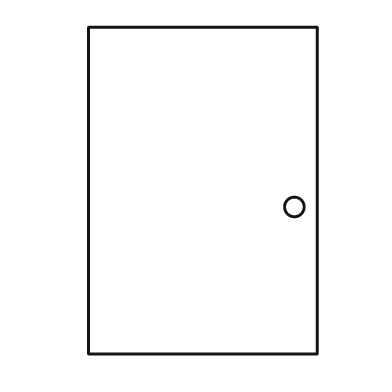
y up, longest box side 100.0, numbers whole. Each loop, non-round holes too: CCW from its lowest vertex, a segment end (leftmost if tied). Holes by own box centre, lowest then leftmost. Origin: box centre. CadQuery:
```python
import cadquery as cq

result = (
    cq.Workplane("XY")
    .moveTo(-35.0, -50.0)
    .lineTo(35.0, -50.0)
    .lineTo(35.0, 50.0)
    .lineTo(-35.0, 50.0)
    .close()
    .moveTo(28.0, -5.0)
    .circle(3.0)
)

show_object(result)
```